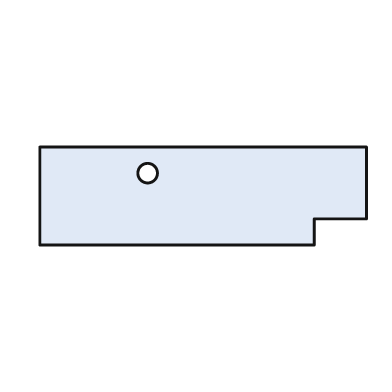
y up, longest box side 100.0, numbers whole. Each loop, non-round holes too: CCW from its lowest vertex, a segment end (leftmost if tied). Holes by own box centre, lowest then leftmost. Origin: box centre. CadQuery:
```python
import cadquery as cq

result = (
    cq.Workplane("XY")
    .moveTo(-50.0, -15.0)
    .lineTo(34.0, -15.0)
    .lineTo(34.0, -7.0)
    .lineTo(50.0, -7.0)
    .lineTo(50.0, 15.0)
    .lineTo(-50.0, 15.0)
    .close()
    .moveTo(-17.0, 7.0)
    .circle(3.0)
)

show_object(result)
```